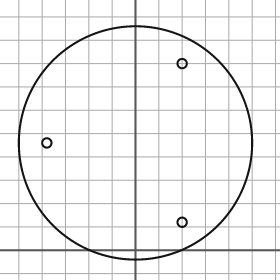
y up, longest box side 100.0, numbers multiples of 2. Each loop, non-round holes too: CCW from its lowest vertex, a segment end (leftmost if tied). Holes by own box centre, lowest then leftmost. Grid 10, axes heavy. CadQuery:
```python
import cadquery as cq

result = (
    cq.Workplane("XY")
    .moveTo(0.0, 46.0)
    .circle(50.0)
    .moveTo(20.0, 12.0)
    .circle(2.0)
    .moveTo(-38.0, 46.0)
    .circle(2.0)
    .moveTo(20.0, 80.0)
    .circle(2.0)
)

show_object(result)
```